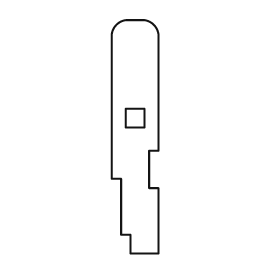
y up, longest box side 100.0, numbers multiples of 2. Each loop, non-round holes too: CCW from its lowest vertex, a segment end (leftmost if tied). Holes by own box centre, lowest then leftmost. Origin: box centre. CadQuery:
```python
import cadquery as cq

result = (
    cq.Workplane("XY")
    .moveTo(-2.0, -50.0)
    .lineTo(10.0, -50.0)
    .lineTo(10.0, -22.0)
    .lineTo(6.0, -22.0)
    .lineTo(6.0, -6.0)
    .lineTo(10.0, -6.0)
    .lineTo(10.0, 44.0)
    .threePointArc((8.0, 48.0), (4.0, 50.0))
    .lineTo(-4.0, 50.0)
    .threePointArc((-8.0, 48.0), (-10.0, 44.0))
    .lineTo(-10.0, -18.0)
    .lineTo(-6.0, -18.0)
    .lineTo(-6.0, -42.0)
    .lineTo(-2.0, -42.0)
    .close()
    .moveTo(-4.0, 4.0)
    .lineTo(4.0, 4.0)
    .lineTo(4.0, 12.0)
    .lineTo(-4.0, 12.0)
    .close()
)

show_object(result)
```